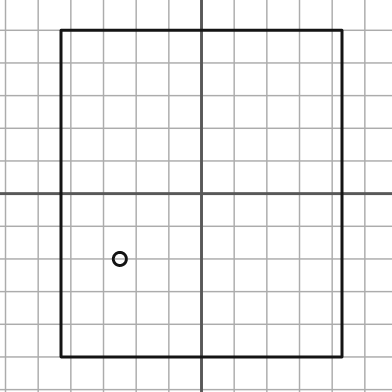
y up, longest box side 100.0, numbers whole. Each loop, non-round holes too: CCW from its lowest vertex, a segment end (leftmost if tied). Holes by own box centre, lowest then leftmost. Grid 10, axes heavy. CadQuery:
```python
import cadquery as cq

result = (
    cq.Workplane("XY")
    .moveTo(-43.0, -50.0)
    .lineTo(43.0, -50.0)
    .lineTo(43.0, 50.0)
    .lineTo(-43.0, 50.0)
    .close()
    .moveTo(-25.0, -20.0)
    .circle(2.0)
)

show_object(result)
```